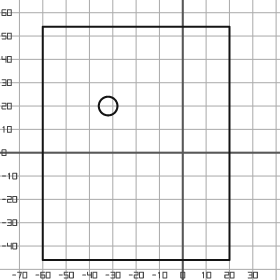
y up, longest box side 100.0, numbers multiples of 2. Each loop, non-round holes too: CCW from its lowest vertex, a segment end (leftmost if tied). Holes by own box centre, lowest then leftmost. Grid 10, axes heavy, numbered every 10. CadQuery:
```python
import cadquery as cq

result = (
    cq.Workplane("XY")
    .moveTo(-60.0, -46.0)
    .lineTo(20.0, -46.0)
    .lineTo(20.0, 54.0)
    .lineTo(-60.0, 54.0)
    .close()
    .moveTo(-32.0, 20.0)
    .circle(4.0)
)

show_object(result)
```